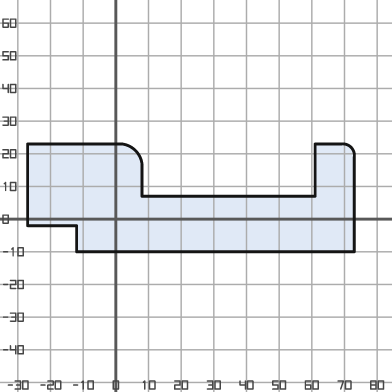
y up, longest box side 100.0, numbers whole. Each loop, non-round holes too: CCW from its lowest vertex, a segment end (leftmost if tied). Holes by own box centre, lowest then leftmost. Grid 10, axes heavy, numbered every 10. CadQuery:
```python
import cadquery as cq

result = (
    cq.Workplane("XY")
    .moveTo(-12.0, -10.0)
    .lineTo(73.0, -10.0)
    .lineTo(73.0, 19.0)
    .threePointArc((72.0, 22.0), (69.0, 23.0))
    .lineTo(61.0, 23.0)
    .lineTo(61.0, 7.0)
    .lineTo(8.0, 7.0)
    .lineTo(8.0, 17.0)
    .threePointArc((6.0, 21.0), (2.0, 23.0))
    .lineTo(-27.0, 23.0)
    .lineTo(-27.0, -2.0)
    .lineTo(-12.0, -2.0)
    .close()
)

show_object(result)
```